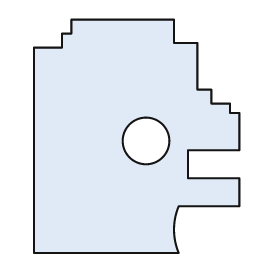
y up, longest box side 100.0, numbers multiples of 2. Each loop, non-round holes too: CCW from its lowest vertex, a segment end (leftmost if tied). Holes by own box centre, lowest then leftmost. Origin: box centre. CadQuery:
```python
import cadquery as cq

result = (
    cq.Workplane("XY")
    .moveTo(-44.0, -50.0)
    .lineTo(18.0, -50.0)
    .threePointArc((16.0, -40.0), (18.0, -30.0))
    .lineTo(44.0, -30.0)
    .lineTo(44.0, -18.0)
    .lineTo(22.0, -18.0)
    .lineTo(22.0, -6.0)
    .lineTo(44.0, -6.0)
    .lineTo(44.0, 10.0)
    .lineTo(40.0, 10.0)
    .lineTo(40.0, 14.0)
    .lineTo(32.0, 14.0)
    .lineTo(32.0, 20.0)
    .lineTo(26.0, 20.0)
    .lineTo(26.0, 40.0)
    .lineTo(16.0, 40.0)
    .lineTo(16.0, 50.0)
    .lineTo(-28.0, 50.0)
    .lineTo(-28.0, 44.0)
    .lineTo(-32.0, 44.0)
    .lineTo(-32.0, 38.0)
    .lineTo(-44.0, 38.0)
    .close()
    .moveTo(4.0, -2.0)
    .circle(10.0)
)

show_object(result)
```